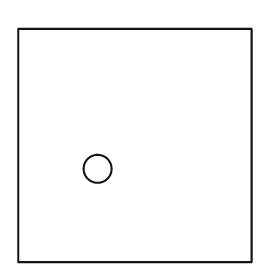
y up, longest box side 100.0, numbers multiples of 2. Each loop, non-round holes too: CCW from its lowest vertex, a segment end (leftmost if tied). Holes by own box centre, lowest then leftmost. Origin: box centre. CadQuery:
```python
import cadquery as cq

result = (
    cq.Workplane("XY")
    .moveTo(-50.0, -50.0)
    .lineTo(50.0, -50.0)
    .lineTo(50.0, 50.0)
    .lineTo(-50.0, 50.0)
    .close()
    .moveTo(-16.0, -10.0)
    .circle(6.0)
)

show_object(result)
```